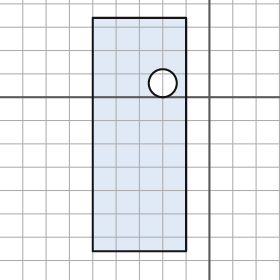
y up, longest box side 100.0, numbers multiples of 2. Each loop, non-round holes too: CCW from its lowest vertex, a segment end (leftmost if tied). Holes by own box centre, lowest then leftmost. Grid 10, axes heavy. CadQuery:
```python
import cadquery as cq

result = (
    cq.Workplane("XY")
    .moveTo(-50.0, -66.0)
    .lineTo(-10.0, -66.0)
    .lineTo(-10.0, 34.0)
    .lineTo(-50.0, 34.0)
    .close()
    .moveTo(-20.0, 6.0)
    .circle(6.0)
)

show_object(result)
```